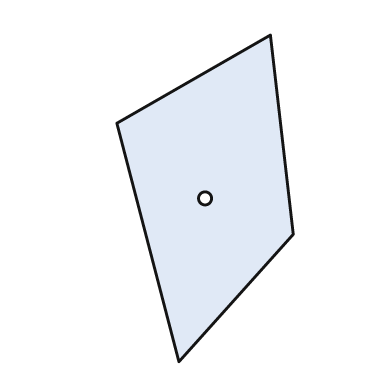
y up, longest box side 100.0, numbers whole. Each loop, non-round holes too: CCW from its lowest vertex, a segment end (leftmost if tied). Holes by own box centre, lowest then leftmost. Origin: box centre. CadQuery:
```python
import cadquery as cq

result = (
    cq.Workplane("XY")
    .moveTo(-8.0, -50.0)
    .lineTo(27.0, -11.0)
    .lineTo(20.0, 50.0)
    .lineTo(-27.0, 23.0)
    .close()
    .moveTo(0.0, 0.0)
    .circle(2.0)
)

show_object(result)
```